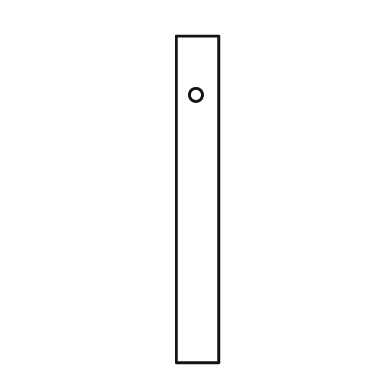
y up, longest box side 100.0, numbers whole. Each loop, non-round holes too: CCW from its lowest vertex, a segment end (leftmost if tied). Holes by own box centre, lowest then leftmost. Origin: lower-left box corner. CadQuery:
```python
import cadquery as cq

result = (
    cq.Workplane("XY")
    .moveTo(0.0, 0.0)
    .lineTo(13.0, 0.0)
    .lineTo(13.0, 100.0)
    .lineTo(0.0, 100.0)
    .close()
    .moveTo(6.0, 82.0)
    .circle(2.0)
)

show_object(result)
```